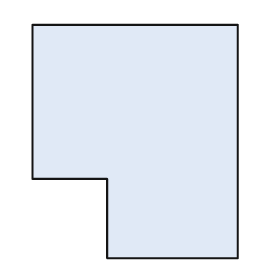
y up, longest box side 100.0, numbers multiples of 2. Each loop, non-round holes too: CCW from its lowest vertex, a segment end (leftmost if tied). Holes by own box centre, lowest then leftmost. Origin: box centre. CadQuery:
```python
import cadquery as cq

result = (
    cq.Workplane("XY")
    .moveTo(-12.0, -50.0)
    .lineTo(44.0, -50.0)
    .lineTo(44.0, 50.0)
    .lineTo(-44.0, 50.0)
    .lineTo(-44.0, -16.0)
    .lineTo(-12.0, -16.0)
    .close()
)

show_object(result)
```